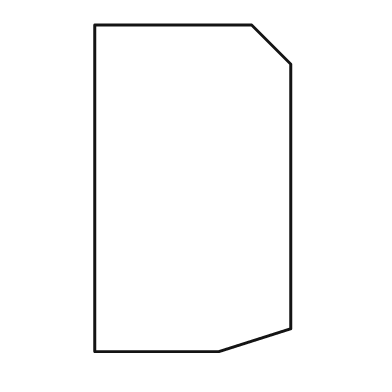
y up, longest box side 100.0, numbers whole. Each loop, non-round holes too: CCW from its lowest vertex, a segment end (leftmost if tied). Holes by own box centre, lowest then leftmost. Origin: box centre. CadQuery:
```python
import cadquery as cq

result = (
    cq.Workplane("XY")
    .moveTo(-30.0, -50.0)
    .lineTo(8.0, -50.0)
    .lineTo(30.0, -43.0)
    .lineTo(30.0, 38.0)
    .lineTo(18.0, 50.0)
    .lineTo(-30.0, 50.0)
    .close()
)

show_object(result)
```